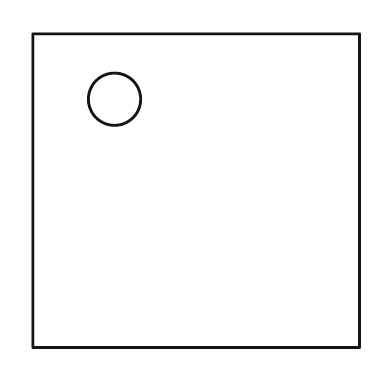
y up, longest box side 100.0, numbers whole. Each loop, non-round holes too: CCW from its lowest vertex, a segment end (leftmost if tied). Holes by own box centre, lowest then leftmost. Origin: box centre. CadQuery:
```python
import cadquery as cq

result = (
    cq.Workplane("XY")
    .moveTo(-50.0, -48.0)
    .lineTo(50.0, -48.0)
    .lineTo(50.0, 48.0)
    .lineTo(-50.0, 48.0)
    .close()
    .moveTo(-25.0, 28.0)
    .circle(8.0)
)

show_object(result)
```